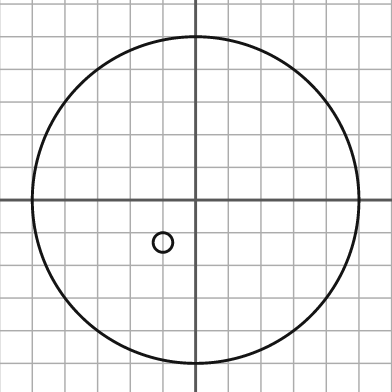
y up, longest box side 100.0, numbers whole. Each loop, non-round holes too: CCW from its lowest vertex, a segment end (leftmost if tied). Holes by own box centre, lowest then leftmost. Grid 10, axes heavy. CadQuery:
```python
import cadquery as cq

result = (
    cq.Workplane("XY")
    .moveTo(0.0, 0.0)
    .circle(50.0)
    .moveTo(-10.0, -13.0)
    .circle(3.0)
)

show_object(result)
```